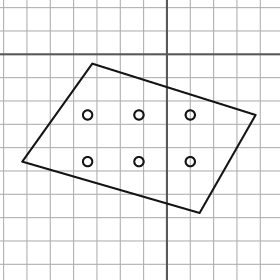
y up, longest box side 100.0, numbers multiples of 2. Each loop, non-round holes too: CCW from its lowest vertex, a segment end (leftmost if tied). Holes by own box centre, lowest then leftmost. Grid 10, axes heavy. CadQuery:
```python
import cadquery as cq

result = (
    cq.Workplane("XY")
    .moveTo(14.0, -68.0)
    .lineTo(38.0, -26.0)
    .lineTo(-32.0, -4.0)
    .lineTo(-62.0, -46.0)
    .close()
    .moveTo(-34.0, -46.0)
    .circle(2.0)
    .moveTo(-12.0, -46.0)
    .circle(2.0)
    .moveTo(10.0, -46.0)
    .circle(2.0)
    .moveTo(-34.0, -26.0)
    .circle(2.0)
    .moveTo(-12.0, -26.0)
    .circle(2.0)
    .moveTo(10.0, -26.0)
    .circle(2.0)
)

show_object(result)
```